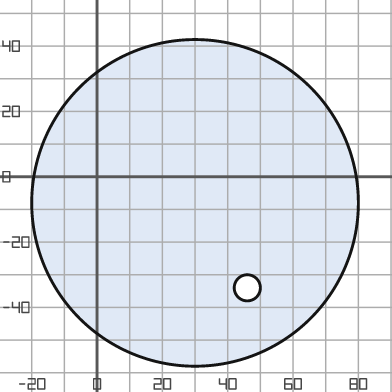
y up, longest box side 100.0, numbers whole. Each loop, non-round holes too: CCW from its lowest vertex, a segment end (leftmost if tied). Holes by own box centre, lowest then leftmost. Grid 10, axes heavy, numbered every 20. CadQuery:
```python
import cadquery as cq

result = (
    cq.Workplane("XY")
    .moveTo(30.0, -8.0)
    .circle(50.0)
    .moveTo(46.0, -34.0)
    .circle(4.0)
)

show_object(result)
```